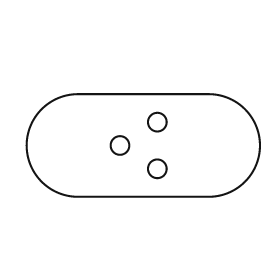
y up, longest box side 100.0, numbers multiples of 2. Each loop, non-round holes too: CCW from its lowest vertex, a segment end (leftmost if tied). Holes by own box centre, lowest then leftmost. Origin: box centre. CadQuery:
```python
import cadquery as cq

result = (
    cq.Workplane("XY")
    .moveTo(-28.0, -22.0)
    .lineTo(28.0, -22.0)
    .threePointArc((50.0, 0.0), (28.0, 22.0))
    .lineTo(-28.0, 22.0)
    .threePointArc((-50.0, 0.0), (-28.0, -22.0))
    .close()
    .moveTo(6.0, -10.0)
    .circle(4.0)
    .moveTo(-10.0, 0.0)
    .circle(4.0)
    .moveTo(6.0, 10.0)
    .circle(4.0)
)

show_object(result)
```